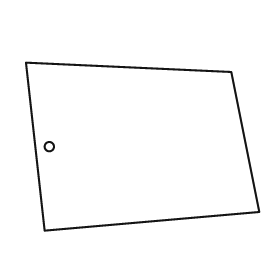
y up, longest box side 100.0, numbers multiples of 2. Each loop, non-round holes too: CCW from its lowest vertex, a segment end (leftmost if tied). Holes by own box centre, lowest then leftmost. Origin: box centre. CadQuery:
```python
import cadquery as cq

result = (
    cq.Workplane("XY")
    .moveTo(-42.0, -36.0)
    .lineTo(50.0, -28.0)
    .lineTo(38.0, 32.0)
    .lineTo(-50.0, 36.0)
    .close()
    .moveTo(-40.0, 0.0)
    .circle(2.0)
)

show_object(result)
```